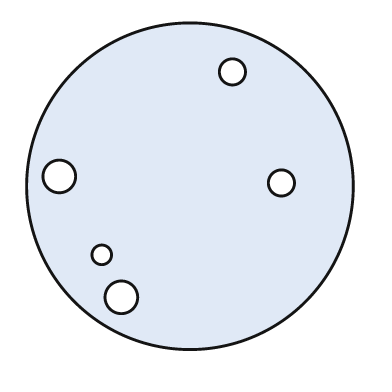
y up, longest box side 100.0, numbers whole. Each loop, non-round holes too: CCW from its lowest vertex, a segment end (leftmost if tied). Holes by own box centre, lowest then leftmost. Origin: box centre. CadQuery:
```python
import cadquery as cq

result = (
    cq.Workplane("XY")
    .moveTo(0.0, 0.0)
    .circle(50.0)
    .moveTo(-21.0, -34.0)
    .circle(5.0)
    .moveTo(-27.0, -21.0)
    .circle(3.0)
    .moveTo(28.0, 1.0)
    .circle(4.0)
    .moveTo(-40.0, 3.0)
    .circle(5.0)
    .moveTo(13.0, 35.0)
    .circle(4.0)
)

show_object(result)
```